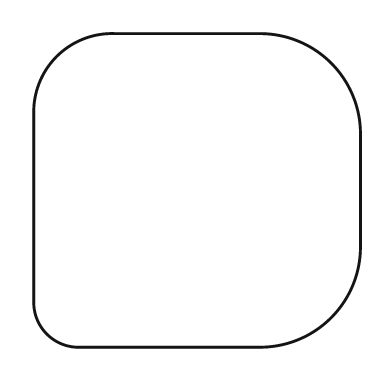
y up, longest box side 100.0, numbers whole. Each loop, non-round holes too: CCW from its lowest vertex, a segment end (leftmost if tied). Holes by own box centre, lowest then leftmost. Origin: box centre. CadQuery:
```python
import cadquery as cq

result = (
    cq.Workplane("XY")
    .moveTo(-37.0, -48.0)
    .lineTo(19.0, -48.0)
    .threePointArc((41.0, -39.0), (50.0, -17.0))
    .lineTo(50.0, 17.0)
    .threePointArc((41.0, 39.0), (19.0, 48.0))
    .lineTo(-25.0, 48.0)
    .threePointArc((-43.0, 41.0), (-50.0, 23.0))
    .lineTo(-50.0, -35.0)
    .threePointArc((-46.0, -44.0), (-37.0, -48.0))
    .close()
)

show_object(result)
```